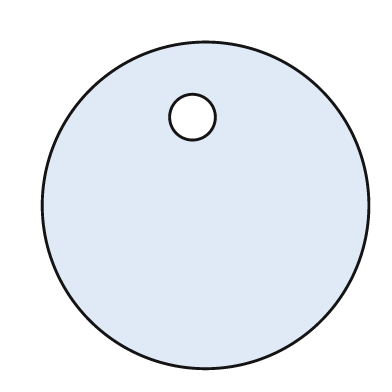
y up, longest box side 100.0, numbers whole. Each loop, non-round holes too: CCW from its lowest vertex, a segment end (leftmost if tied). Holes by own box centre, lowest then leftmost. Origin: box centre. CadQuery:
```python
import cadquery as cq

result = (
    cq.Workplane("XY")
    .moveTo(0.0, 0.0)
    .circle(50.0)
    .moveTo(-4.0, 27.0)
    .circle(7.0)
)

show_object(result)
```